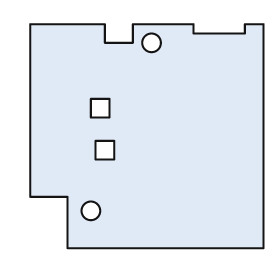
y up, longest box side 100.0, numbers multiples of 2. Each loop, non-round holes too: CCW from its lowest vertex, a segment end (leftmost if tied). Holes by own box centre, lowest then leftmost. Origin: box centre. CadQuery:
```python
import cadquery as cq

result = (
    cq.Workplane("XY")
    .moveTo(-34.0, -48.0)
    .lineTo(50.0, -48.0)
    .lineTo(50.0, 48.0)
    .lineTo(42.0, 48.0)
    .lineTo(42.0, 44.0)
    .lineTo(20.0, 44.0)
    .lineTo(20.0, 48.0)
    .lineTo(-6.0, 48.0)
    .lineTo(-6.0, 40.0)
    .lineTo(-18.0, 40.0)
    .lineTo(-18.0, 48.0)
    .lineTo(-50.0, 48.0)
    .lineTo(-50.0, -26.0)
    .lineTo(-34.0, -26.0)
    .close()
    .moveTo(-24.0, -32.0)
    .circle(4.0)
    .moveTo(-22.0, -10.0)
    .lineTo(-14.0, -10.0)
    .lineTo(-14.0, -2.0)
    .lineTo(-22.0, -2.0)
    .close()
    .moveTo(-24.0, 8.0)
    .lineTo(-16.0, 8.0)
    .lineTo(-16.0, 16.0)
    .lineTo(-24.0, 16.0)
    .close()
    .moveTo(2.0, 40.0)
    .circle(4.0)
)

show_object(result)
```